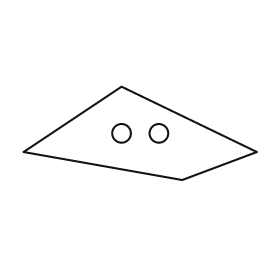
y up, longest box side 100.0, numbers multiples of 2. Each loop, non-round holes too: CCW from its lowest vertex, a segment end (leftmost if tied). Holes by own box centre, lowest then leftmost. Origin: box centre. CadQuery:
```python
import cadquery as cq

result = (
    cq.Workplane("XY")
    .moveTo(18.0, -20.0)
    .lineTo(50.0, -8.0)
    .lineTo(-8.0, 20.0)
    .lineTo(-50.0, -8.0)
    .close()
    .moveTo(-8.0, 0.0)
    .circle(4.0)
    .moveTo(8.0, 0.0)
    .circle(4.0)
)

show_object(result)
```